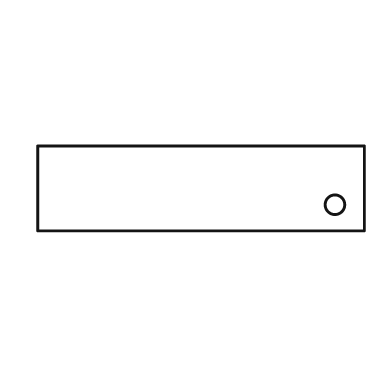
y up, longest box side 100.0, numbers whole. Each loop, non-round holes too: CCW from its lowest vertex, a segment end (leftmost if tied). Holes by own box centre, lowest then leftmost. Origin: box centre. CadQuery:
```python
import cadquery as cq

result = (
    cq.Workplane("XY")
    .moveTo(-50.0, -13.0)
    .lineTo(50.0, -13.0)
    .lineTo(50.0, 13.0)
    .lineTo(-50.0, 13.0)
    .close()
    .moveTo(41.0, -5.0)
    .circle(3.0)
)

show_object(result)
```